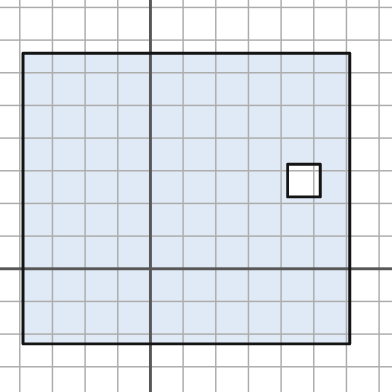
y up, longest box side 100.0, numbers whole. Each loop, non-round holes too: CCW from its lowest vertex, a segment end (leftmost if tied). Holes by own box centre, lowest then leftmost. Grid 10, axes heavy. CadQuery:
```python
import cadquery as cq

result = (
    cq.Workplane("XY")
    .moveTo(-39.0, -23.0)
    .lineTo(61.0, -23.0)
    .lineTo(61.0, 66.0)
    .lineTo(-39.0, 66.0)
    .close()
    .moveTo(42.0, 22.0)
    .lineTo(52.0, 22.0)
    .lineTo(52.0, 32.0)
    .lineTo(42.0, 32.0)
    .close()
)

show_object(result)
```